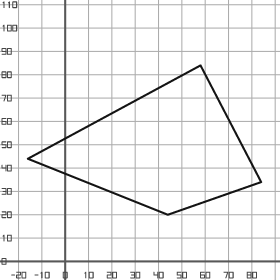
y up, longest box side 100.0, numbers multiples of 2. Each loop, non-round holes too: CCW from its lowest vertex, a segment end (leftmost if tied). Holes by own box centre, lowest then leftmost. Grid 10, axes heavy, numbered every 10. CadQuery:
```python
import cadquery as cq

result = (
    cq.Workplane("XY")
    .moveTo(44.0, 20.0)
    .lineTo(84.0, 34.0)
    .lineTo(58.0, 84.0)
    .lineTo(-16.0, 44.0)
    .close()
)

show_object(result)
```